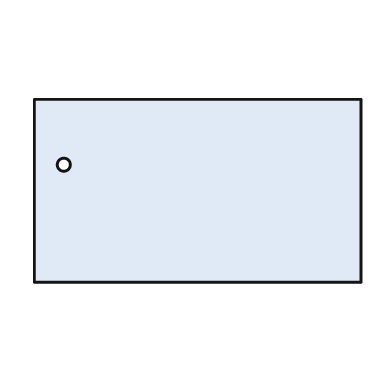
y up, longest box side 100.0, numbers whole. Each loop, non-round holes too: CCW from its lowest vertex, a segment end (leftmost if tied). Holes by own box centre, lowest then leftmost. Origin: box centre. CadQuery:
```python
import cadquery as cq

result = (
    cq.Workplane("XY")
    .moveTo(-50.0, -28.0)
    .lineTo(50.0, -28.0)
    .lineTo(50.0, 28.0)
    .lineTo(-50.0, 28.0)
    .close()
    .moveTo(-41.0, 8.0)
    .circle(2.0)
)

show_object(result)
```